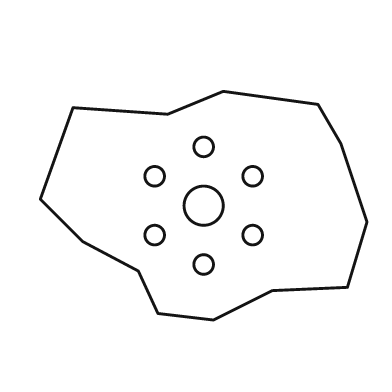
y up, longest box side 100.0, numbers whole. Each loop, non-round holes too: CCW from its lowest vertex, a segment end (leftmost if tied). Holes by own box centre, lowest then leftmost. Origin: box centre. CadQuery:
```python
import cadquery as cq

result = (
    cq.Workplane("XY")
    .moveTo(3.0, -35.0)
    .lineTo(21.0, -26.0)
    .lineTo(44.0, -25.0)
    .lineTo(50.0, -5.0)
    .lineTo(42.0, 19.0)
    .lineTo(35.0, 31.0)
    .lineTo(6.0, 35.0)
    .lineTo(-11.0, 28.0)
    .lineTo(-40.0, 30.0)
    .lineTo(-50.0, 2.0)
    .lineTo(-37.0, -11.0)
    .lineTo(-20.0, -20.0)
    .lineTo(-14.0, -33.0)
    .close()
    .moveTo(0.0, -18.0)
    .circle(3.0)
    .moveTo(-15.0, -9.0)
    .circle(3.0)
    .moveTo(15.0, -9.0)
    .circle(3.0)
    .moveTo(0.0, 0.0)
    .circle(6.0)
    .moveTo(-15.0, 9.0)
    .circle(3.0)
    .moveTo(15.0, 9.0)
    .circle(3.0)
    .moveTo(0.0, 18.0)
    .circle(3.0)
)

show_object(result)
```